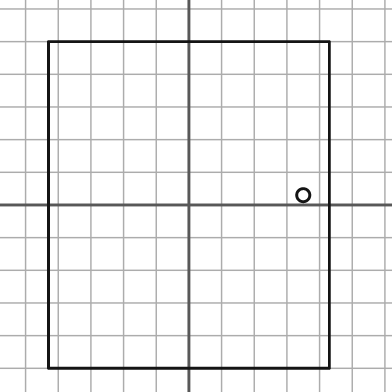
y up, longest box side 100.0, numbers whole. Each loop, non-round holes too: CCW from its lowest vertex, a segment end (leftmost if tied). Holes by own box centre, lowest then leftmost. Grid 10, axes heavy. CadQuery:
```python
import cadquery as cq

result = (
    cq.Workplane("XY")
    .moveTo(-43.0, -50.0)
    .lineTo(43.0, -50.0)
    .lineTo(43.0, 50.0)
    .lineTo(-43.0, 50.0)
    .close()
    .moveTo(35.0, 3.0)
    .circle(2.0)
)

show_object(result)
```